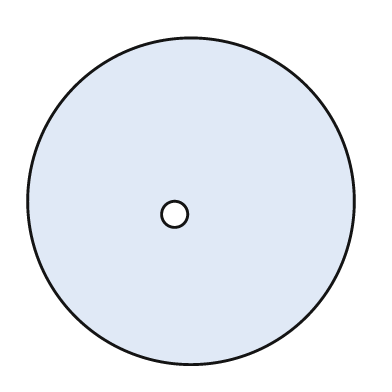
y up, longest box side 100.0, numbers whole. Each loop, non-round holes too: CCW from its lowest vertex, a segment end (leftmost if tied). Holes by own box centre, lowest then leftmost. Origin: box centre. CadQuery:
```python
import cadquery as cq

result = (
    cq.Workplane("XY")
    .moveTo(0.0, 0.0)
    .circle(50.0)
    .moveTo(-5.0, -4.0)
    .circle(4.0)
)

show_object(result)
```